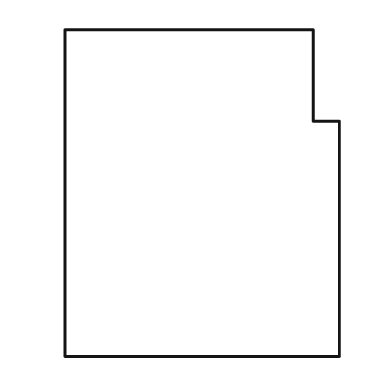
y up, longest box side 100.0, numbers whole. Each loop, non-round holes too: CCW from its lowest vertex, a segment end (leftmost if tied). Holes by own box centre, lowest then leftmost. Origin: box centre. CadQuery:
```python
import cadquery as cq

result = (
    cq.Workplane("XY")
    .moveTo(-42.0, -50.0)
    .lineTo(42.0, -50.0)
    .lineTo(42.0, 22.0)
    .lineTo(34.0, 22.0)
    .lineTo(34.0, 50.0)
    .lineTo(-42.0, 50.0)
    .close()
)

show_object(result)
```